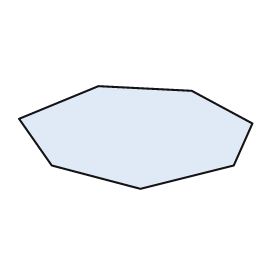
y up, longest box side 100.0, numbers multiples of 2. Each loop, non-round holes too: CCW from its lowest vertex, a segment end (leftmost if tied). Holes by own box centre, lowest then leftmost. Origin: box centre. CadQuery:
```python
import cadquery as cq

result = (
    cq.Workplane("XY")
    .moveTo(2.0, -22.0)
    .lineTo(42.0, -12.0)
    .lineTo(50.0, 6.0)
    .lineTo(24.0, 20.0)
    .lineTo(-16.0, 22.0)
    .lineTo(-50.0, 8.0)
    .lineTo(-36.0, -12.0)
    .close()
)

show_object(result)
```